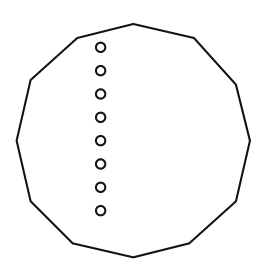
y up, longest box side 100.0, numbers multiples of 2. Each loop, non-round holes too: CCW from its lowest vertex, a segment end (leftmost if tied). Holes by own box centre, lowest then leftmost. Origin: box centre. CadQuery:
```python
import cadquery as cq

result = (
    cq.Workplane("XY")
    .moveTo(0.0, -50.0)
    .lineTo(24.0, -44.0)
    .lineTo(44.0, -26.0)
    .lineTo(50.0, 0.0)
    .lineTo(44.0, 24.0)
    .lineTo(26.0, 44.0)
    .lineTo(0.0, 50.0)
    .lineTo(-24.0, 44.0)
    .lineTo(-44.0, 26.0)
    .lineTo(-50.0, 0.0)
    .lineTo(-44.0, -26.0)
    .lineTo(-26.0, -44.0)
    .close()
    .moveTo(-14.0, -30.0)
    .circle(2.0)
    .moveTo(-14.0, -20.0)
    .circle(2.0)
    .moveTo(-14.0, -10.0)
    .circle(2.0)
    .moveTo(-14.0, 0.0)
    .circle(2.0)
    .moveTo(-14.0, 10.0)
    .circle(2.0)
    .moveTo(-14.0, 20.0)
    .circle(2.0)
    .moveTo(-14.0, 30.0)
    .circle(2.0)
    .moveTo(-14.0, 40.0)
    .circle(2.0)
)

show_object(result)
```